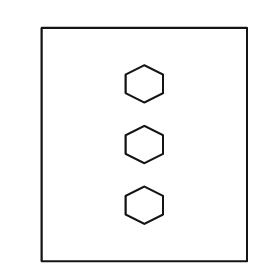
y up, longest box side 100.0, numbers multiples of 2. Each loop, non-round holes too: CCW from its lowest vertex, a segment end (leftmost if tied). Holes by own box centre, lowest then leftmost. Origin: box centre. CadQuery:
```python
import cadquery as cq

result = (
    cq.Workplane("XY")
    .moveTo(-44.0, -50.0)
    .lineTo(44.0, -50.0)
    .lineTo(44.0, 50.0)
    .lineTo(-44.0, 50.0)
    .close()
    .moveTo(0.0, -34.0)
    .lineTo(8.0, -30.0)
    .lineTo(8.0, -22.0)
    .lineTo(0.0, -18.0)
    .lineTo(-8.0, -22.0)
    .lineTo(-8.0, -30.0)
    .close()
    .moveTo(0.0, -8.0)
    .lineTo(8.0, -4.0)
    .lineTo(8.0, 4.0)
    .lineTo(0.0, 8.0)
    .lineTo(-8.0, 4.0)
    .lineTo(-8.0, -4.0)
    .close()
    .moveTo(0.0, 18.0)
    .lineTo(8.0, 22.0)
    .lineTo(8.0, 30.0)
    .lineTo(0.0, 34.0)
    .lineTo(-8.0, 30.0)
    .lineTo(-8.0, 22.0)
    .close()
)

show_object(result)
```